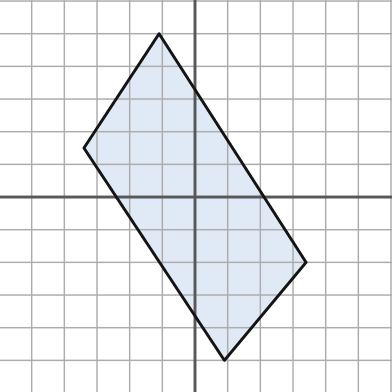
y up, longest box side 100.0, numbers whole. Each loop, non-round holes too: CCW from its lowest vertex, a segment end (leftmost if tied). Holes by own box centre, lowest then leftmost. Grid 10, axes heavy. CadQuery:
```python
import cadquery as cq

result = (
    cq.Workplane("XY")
    .moveTo(9.0, -50.0)
    .lineTo(34.0, -20.0)
    .lineTo(-11.0, 50.0)
    .lineTo(-34.0, 15.0)
    .close()
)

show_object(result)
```